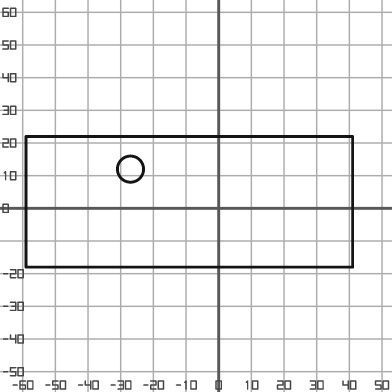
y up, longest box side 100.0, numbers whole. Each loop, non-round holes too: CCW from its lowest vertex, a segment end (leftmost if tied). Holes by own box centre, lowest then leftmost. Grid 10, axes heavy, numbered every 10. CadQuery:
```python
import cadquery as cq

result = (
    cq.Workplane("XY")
    .moveTo(-59.0, -18.0)
    .lineTo(41.0, -18.0)
    .lineTo(41.0, 22.0)
    .lineTo(-59.0, 22.0)
    .close()
    .moveTo(-27.0, 12.0)
    .circle(4.0)
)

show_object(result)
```